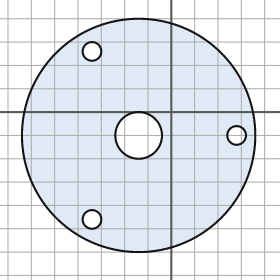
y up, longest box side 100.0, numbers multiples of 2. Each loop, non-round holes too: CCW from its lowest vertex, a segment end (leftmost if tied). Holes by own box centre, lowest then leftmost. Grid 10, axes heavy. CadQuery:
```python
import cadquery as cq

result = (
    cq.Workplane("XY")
    .moveTo(-14.0, -10.0)
    .circle(50.0)
    .moveTo(-34.0, -46.0)
    .circle(4.0)
    .moveTo(-14.0, -10.0)
    .circle(10.0)
    .moveTo(28.0, -10.0)
    .circle(4.0)
    .moveTo(-34.0, 26.0)
    .circle(4.0)
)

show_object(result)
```